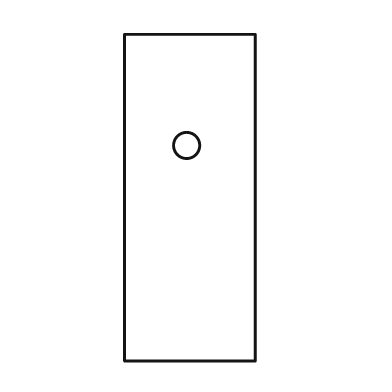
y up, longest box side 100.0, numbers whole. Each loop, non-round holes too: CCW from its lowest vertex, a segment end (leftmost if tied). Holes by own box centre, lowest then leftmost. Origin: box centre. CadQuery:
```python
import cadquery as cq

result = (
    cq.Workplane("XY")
    .moveTo(-20.0, -50.0)
    .lineTo(20.0, -50.0)
    .lineTo(20.0, 50.0)
    .lineTo(-20.0, 50.0)
    .close()
    .moveTo(-1.0, 16.0)
    .circle(4.0)
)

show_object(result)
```